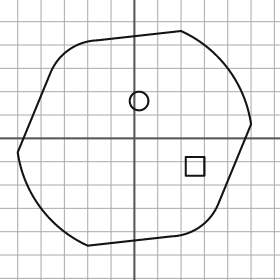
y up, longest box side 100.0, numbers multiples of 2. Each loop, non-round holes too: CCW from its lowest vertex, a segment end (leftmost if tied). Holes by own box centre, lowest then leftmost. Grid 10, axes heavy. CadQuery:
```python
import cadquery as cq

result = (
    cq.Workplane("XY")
    .moveTo(-20.0, -46.0)
    .lineTo(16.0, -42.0)
    .threePointArc((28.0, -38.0), (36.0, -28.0))
    .lineTo(50.0, 6.0)
    .threePointArc((40.0, 30.0), (20.0, 46.0))
    .lineTo(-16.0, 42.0)
    .threePointArc((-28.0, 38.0), (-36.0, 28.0))
    .lineTo(-50.0, -6.0)
    .threePointArc((-40.0, -30.0), (-20.0, -46.0))
    .close()
    .moveTo(22.0, -16.0)
    .lineTo(30.0, -16.0)
    .lineTo(30.0, -8.0)
    .lineTo(22.0, -8.0)
    .close()
    .moveTo(2.0, 16.0)
    .circle(4.0)
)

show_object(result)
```